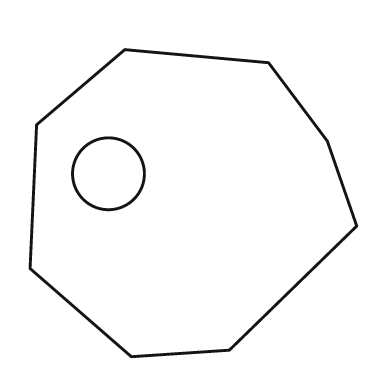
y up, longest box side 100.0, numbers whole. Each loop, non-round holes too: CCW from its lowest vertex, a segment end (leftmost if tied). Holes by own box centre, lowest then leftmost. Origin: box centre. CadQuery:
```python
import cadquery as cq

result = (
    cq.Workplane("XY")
    .moveTo(-19.0, -47.0)
    .lineTo(11.0, -45.0)
    .lineTo(50.0, -7.0)
    .lineTo(41.0, 19.0)
    .lineTo(23.0, 43.0)
    .lineTo(-21.0, 47.0)
    .lineTo(-48.0, 24.0)
    .lineTo(-50.0, -20.0)
    .close()
    .moveTo(-26.0, 9.0)
    .circle(11.0)
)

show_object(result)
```